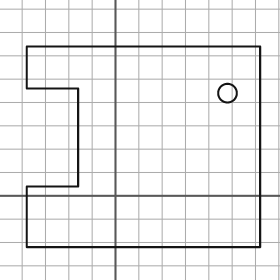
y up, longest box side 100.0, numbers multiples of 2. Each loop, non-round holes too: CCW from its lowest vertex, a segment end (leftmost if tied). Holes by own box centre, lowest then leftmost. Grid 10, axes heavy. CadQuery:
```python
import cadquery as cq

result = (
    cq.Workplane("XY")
    .moveTo(-38.0, -22.0)
    .lineTo(62.0, -22.0)
    .lineTo(62.0, 64.0)
    .lineTo(-38.0, 64.0)
    .lineTo(-38.0, 46.0)
    .lineTo(-16.0, 46.0)
    .lineTo(-16.0, 4.0)
    .lineTo(-38.0, 4.0)
    .close()
    .moveTo(48.0, 44.0)
    .circle(4.0)
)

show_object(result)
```